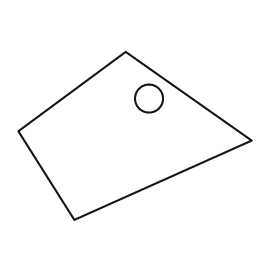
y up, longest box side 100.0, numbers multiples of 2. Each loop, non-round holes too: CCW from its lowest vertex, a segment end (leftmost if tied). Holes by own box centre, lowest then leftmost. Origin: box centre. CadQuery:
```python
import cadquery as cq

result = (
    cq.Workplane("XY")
    .moveTo(-26.0, -36.0)
    .lineTo(50.0, -2.0)
    .lineTo(-4.0, 36.0)
    .lineTo(-50.0, 2.0)
    .close()
    .moveTo(6.0, 16.0)
    .circle(6.0)
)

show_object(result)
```